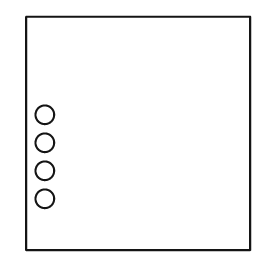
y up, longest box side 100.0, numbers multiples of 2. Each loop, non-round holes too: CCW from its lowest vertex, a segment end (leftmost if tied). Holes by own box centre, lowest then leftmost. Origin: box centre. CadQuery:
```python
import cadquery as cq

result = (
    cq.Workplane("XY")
    .moveTo(-48.0, -50.0)
    .lineTo(48.0, -50.0)
    .lineTo(48.0, 50.0)
    .lineTo(-48.0, 50.0)
    .close()
    .moveTo(-40.0, -28.0)
    .circle(4.0)
    .moveTo(-40.0, -16.0)
    .circle(4.0)
    .moveTo(-40.0, -4.0)
    .circle(4.0)
    .moveTo(-40.0, 8.0)
    .circle(4.0)
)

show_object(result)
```